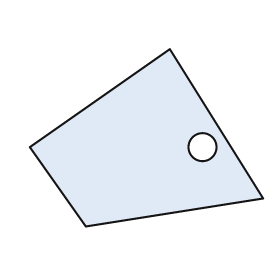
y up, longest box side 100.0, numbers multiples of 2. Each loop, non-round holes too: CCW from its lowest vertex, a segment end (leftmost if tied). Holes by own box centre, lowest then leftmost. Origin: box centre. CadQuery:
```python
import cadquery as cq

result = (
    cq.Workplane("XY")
    .moveTo(-26.0, -38.0)
    .lineTo(50.0, -26.0)
    .lineTo(10.0, 38.0)
    .lineTo(-50.0, -4.0)
    .close()
    .moveTo(24.0, -4.0)
    .circle(6.0)
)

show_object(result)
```